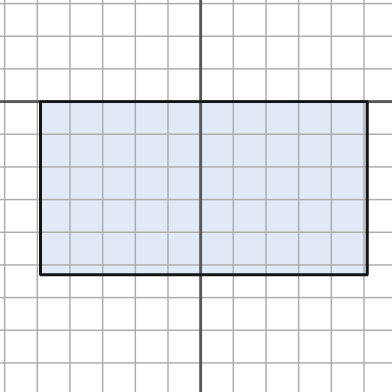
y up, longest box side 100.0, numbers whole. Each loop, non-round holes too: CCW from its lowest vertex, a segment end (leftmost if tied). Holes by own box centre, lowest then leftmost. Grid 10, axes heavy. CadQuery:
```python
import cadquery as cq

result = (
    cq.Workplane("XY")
    .moveTo(-49.0, -53.0)
    .lineTo(51.0, -53.0)
    .lineTo(51.0, 0.0)
    .lineTo(-49.0, 0.0)
    .close()
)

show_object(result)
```